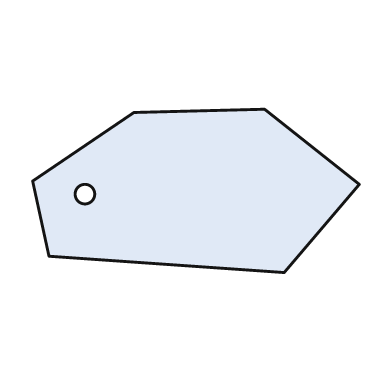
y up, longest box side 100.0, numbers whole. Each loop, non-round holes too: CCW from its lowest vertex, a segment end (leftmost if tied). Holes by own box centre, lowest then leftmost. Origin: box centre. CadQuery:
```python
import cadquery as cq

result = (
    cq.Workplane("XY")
    .moveTo(27.0, -25.0)
    .lineTo(50.0, 2.0)
    .lineTo(21.0, 25.0)
    .lineTo(-19.0, 24.0)
    .lineTo(-50.0, 3.0)
    .lineTo(-45.0, -20.0)
    .close()
    .moveTo(-34.0, -1.0)
    .circle(3.0)
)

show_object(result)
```